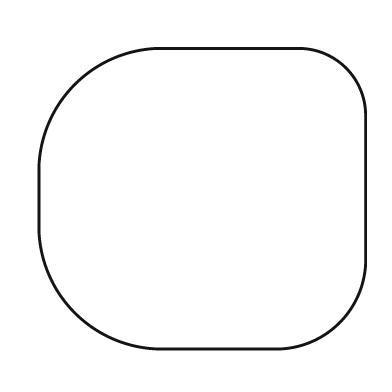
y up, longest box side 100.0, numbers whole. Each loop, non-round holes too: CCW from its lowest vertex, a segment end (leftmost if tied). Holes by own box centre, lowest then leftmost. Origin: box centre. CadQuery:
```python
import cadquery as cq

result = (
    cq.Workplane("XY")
    .moveTo(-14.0, -46.0)
    .lineTo(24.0, -46.0)
    .threePointArc((42.0, -38.0), (50.0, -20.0))
    .lineTo(50.0, 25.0)
    .threePointArc((44.0, 40.0), (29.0, 46.0))
    .lineTo(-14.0, 46.0)
    .threePointArc((-39.0, 35.0), (-50.0, 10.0))
    .lineTo(-50.0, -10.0)
    .threePointArc((-39.0, -35.0), (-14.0, -46.0))
    .close()
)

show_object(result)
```